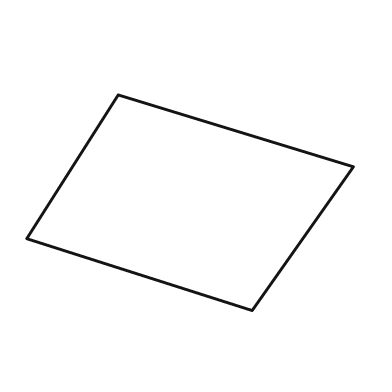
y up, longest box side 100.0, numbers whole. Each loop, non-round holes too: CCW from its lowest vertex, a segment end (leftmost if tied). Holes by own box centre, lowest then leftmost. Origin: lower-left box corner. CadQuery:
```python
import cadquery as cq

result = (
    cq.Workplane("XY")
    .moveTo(69.0, 0.0)
    .lineTo(100.0, 44.0)
    .lineTo(28.0, 66.0)
    .lineTo(0.0, 22.0)
    .close()
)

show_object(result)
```